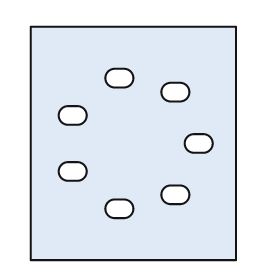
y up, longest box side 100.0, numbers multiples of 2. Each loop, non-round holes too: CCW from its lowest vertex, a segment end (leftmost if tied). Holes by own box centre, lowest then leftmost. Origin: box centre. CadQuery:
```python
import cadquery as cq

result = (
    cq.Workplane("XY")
    .moveTo(-44.0, -50.0)
    .lineTo(44.0, -50.0)
    .lineTo(44.0, 50.0)
    .lineTo(-44.0, 50.0)
    .close()
    .moveTo(-8.0, -32.0)
    .lineTo(-4.0, -32.0)
    .threePointArc((0.0, -28.0), (-4.0, -24.0))
    .lineTo(-8.0, -24.0)
    .threePointArc((-12.0, -28.0), (-8.0, -32.0))
    .close()
    .moveTo(16.0, -26.0)
    .lineTo(20.0, -26.0)
    .threePointArc((24.0, -22.0), (20.0, -18.0))
    .lineTo(16.0, -18.0)
    .threePointArc((12.0, -22.0), (16.0, -26.0))
    .close()
    .moveTo(-28.0, -16.0)
    .lineTo(-24.0, -16.0)
    .threePointArc((-20.0, -12.0), (-24.0, -8.0))
    .lineTo(-28.0, -8.0)
    .threePointArc((-32.0, -12.0), (-28.0, -16.0))
    .close()
    .moveTo(26.0, -4.0)
    .lineTo(30.0, -4.0)
    .threePointArc((34.0, 0.0), (30.0, 4.0))
    .lineTo(26.0, 4.0)
    .threePointArc((22.0, 0.0), (26.0, -4.0))
    .close()
    .moveTo(-28.0, 8.0)
    .lineTo(-24.0, 8.0)
    .threePointArc((-20.0, 12.0), (-24.0, 16.0))
    .lineTo(-28.0, 16.0)
    .threePointArc((-32.0, 12.0), (-28.0, 8.0))
    .close()
    .moveTo(16.0, 18.0)
    .lineTo(20.0, 18.0)
    .threePointArc((24.0, 22.0), (20.0, 26.0))
    .lineTo(16.0, 26.0)
    .threePointArc((12.0, 22.0), (16.0, 18.0))
    .close()
    .moveTo(-8.0, 24.0)
    .lineTo(-4.0, 24.0)
    .threePointArc((0.0, 28.0), (-4.0, 32.0))
    .lineTo(-8.0, 32.0)
    .threePointArc((-12.0, 28.0), (-8.0, 24.0))
    .close()
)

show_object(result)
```